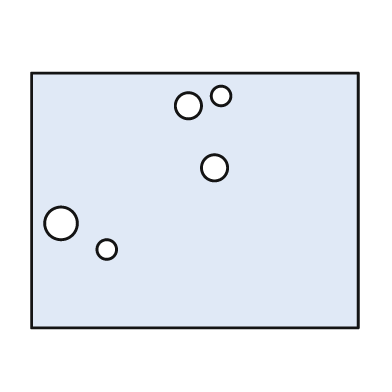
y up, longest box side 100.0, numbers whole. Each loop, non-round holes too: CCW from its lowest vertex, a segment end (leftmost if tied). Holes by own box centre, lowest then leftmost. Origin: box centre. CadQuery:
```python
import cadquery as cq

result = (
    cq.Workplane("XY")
    .moveTo(-50.0, -39.0)
    .lineTo(50.0, -39.0)
    .lineTo(50.0, 39.0)
    .lineTo(-50.0, 39.0)
    .close()
    .moveTo(-27.0, -15.0)
    .circle(3.0)
    .moveTo(-41.0, -7.0)
    .circle(5.0)
    .moveTo(6.0, 10.0)
    .circle(4.0)
    .moveTo(-2.0, 29.0)
    .circle(4.0)
    .moveTo(8.0, 32.0)
    .circle(3.0)
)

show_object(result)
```